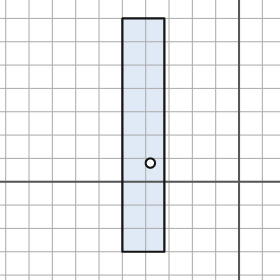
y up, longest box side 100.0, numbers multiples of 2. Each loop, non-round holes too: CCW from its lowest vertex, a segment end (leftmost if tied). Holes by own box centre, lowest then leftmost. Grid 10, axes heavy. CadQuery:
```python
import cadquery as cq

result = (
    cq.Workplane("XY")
    .moveTo(-50.0, -30.0)
    .lineTo(-32.0, -30.0)
    .lineTo(-32.0, 70.0)
    .lineTo(-50.0, 70.0)
    .close()
    .moveTo(-38.0, 8.0)
    .circle(2.0)
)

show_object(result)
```